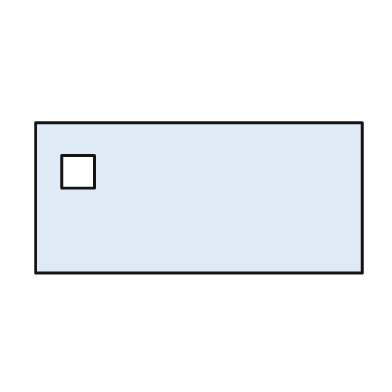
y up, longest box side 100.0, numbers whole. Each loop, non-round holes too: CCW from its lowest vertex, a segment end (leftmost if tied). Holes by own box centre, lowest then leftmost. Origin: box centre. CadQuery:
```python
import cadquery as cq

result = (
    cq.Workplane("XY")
    .moveTo(-50.0, -23.0)
    .lineTo(50.0, -23.0)
    .lineTo(50.0, 23.0)
    .lineTo(-50.0, 23.0)
    .close()
    .moveTo(-42.0, 3.0)
    .lineTo(-32.0, 3.0)
    .lineTo(-32.0, 13.0)
    .lineTo(-42.0, 13.0)
    .close()
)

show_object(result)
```